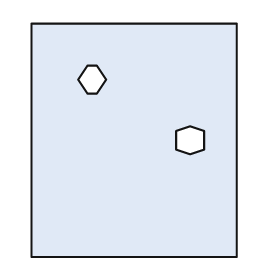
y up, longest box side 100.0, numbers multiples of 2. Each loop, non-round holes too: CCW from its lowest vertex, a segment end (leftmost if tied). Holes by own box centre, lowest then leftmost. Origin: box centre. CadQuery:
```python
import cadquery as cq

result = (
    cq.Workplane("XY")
    .moveTo(-44.0, -50.0)
    .lineTo(44.0, -50.0)
    .lineTo(44.0, 50.0)
    .lineTo(-44.0, 50.0)
    .close()
    .moveTo(24.0, -6.0)
    .lineTo(30.0, -4.0)
    .lineTo(30.0, 4.0)
    .lineTo(24.0, 6.0)
    .lineTo(18.0, 4.0)
    .lineTo(18.0, -4.0)
    .close()
    .moveTo(-20.0, 20.0)
    .lineTo(-16.0, 20.0)
    .lineTo(-12.0, 26.0)
    .lineTo(-16.0, 32.0)
    .lineTo(-20.0, 32.0)
    .lineTo(-24.0, 26.0)
    .close()
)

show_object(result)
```